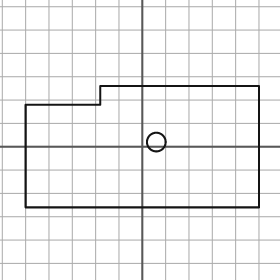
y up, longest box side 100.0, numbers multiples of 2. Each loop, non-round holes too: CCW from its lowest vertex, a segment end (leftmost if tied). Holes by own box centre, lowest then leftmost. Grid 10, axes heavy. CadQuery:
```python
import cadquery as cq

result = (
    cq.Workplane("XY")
    .moveTo(-50.0, -26.0)
    .lineTo(50.0, -26.0)
    .lineTo(50.0, 26.0)
    .lineTo(-18.0, 26.0)
    .lineTo(-18.0, 18.0)
    .lineTo(-50.0, 18.0)
    .close()
    .moveTo(6.0, 2.0)
    .circle(4.0)
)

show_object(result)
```